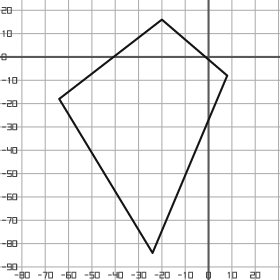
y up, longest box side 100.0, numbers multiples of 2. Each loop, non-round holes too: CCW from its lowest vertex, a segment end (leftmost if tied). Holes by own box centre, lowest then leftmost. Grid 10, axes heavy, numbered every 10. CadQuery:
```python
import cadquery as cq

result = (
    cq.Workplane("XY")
    .moveTo(-24.0, -84.0)
    .lineTo(8.0, -8.0)
    .lineTo(-20.0, 16.0)
    .lineTo(-64.0, -18.0)
    .close()
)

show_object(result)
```